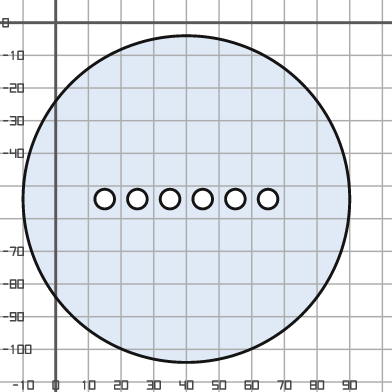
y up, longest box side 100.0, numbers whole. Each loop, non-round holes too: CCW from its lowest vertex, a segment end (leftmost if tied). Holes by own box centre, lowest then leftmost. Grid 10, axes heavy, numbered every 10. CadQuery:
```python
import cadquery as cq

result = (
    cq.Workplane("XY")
    .moveTo(40.0, -54.0)
    .circle(50.0)
    .moveTo(15.0, -54.0)
    .circle(3.0)
    .moveTo(25.0, -54.0)
    .circle(3.0)
    .moveTo(35.0, -54.0)
    .circle(3.0)
    .moveTo(45.0, -54.0)
    .circle(3.0)
    .moveTo(55.0, -54.0)
    .circle(3.0)
    .moveTo(65.0, -54.0)
    .circle(3.0)
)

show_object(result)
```